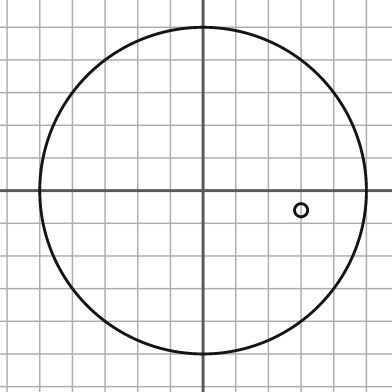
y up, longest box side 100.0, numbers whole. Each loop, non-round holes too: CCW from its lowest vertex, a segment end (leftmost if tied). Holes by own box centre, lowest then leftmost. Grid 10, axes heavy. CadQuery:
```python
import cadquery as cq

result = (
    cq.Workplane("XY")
    .moveTo(0.0, 0.0)
    .circle(50.0)
    .moveTo(30.0, -6.0)
    .circle(2.0)
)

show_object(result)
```